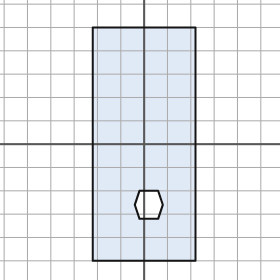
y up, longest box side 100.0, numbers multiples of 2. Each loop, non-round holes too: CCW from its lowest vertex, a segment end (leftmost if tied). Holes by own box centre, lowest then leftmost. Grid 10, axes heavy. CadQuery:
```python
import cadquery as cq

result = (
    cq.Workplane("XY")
    .moveTo(-22.0, -50.0)
    .lineTo(22.0, -50.0)
    .lineTo(22.0, 50.0)
    .lineTo(-22.0, 50.0)
    .close()
    .moveTo(-2.0, -32.0)
    .lineTo(6.0, -32.0)
    .lineTo(8.0, -26.0)
    .lineTo(6.0, -20.0)
    .lineTo(-2.0, -20.0)
    .lineTo(-4.0, -26.0)
    .close()
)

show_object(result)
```